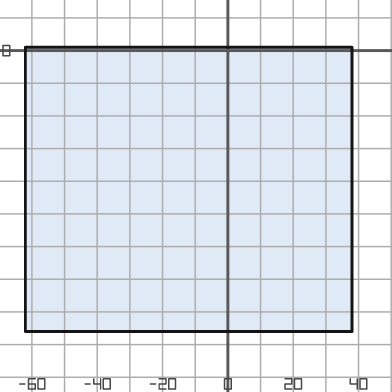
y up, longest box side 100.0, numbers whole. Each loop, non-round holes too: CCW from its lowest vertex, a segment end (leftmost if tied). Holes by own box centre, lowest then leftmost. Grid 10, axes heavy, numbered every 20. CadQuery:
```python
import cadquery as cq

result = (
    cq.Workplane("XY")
    .moveTo(-62.0, -86.0)
    .lineTo(38.0, -86.0)
    .lineTo(38.0, 1.0)
    .lineTo(-62.0, 1.0)
    .close()
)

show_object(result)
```